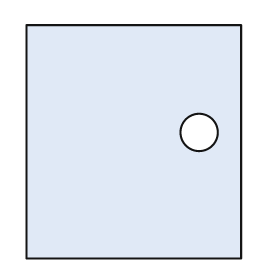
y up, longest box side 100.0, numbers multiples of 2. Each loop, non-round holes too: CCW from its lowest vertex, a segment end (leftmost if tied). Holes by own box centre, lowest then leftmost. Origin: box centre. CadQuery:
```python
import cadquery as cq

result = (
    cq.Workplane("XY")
    .moveTo(-46.0, -50.0)
    .lineTo(46.0, -50.0)
    .lineTo(46.0, 50.0)
    .lineTo(-46.0, 50.0)
    .close()
    .moveTo(28.0, 4.0)
    .circle(8.0)
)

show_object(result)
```